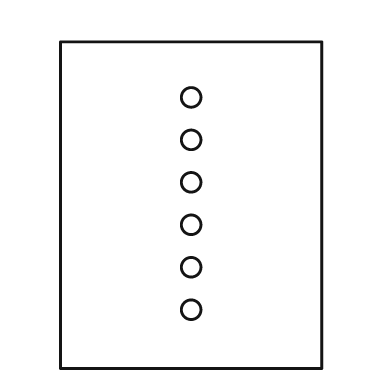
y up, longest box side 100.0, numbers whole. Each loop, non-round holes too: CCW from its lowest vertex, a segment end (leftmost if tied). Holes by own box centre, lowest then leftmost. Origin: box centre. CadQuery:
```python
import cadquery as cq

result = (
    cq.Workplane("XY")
    .moveTo(-40.0, -50.0)
    .lineTo(40.0, -50.0)
    .lineTo(40.0, 50.0)
    .lineTo(-40.0, 50.0)
    .close()
    .moveTo(0.0, -32.0)
    .circle(3.0)
    .moveTo(0.0, -19.0)
    .circle(3.0)
    .moveTo(0.0, -6.0)
    .circle(3.0)
    .moveTo(0.0, 7.0)
    .circle(3.0)
    .moveTo(0.0, 20.0)
    .circle(3.0)
    .moveTo(0.0, 33.0)
    .circle(3.0)
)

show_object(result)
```